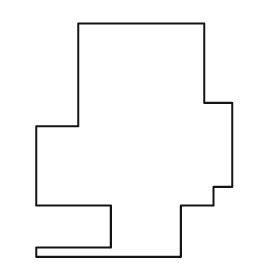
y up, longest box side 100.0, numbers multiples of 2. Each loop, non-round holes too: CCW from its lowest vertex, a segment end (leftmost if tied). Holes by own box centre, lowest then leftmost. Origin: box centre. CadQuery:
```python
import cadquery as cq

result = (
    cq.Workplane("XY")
    .moveTo(-42.0, -50.0)
    .lineTo(20.0, -50.0)
    .lineTo(20.0, -28.0)
    .lineTo(34.0, -28.0)
    .lineTo(34.0, -20.0)
    .lineTo(42.0, -20.0)
    .lineTo(42.0, 16.0)
    .lineTo(30.0, 16.0)
    .lineTo(30.0, 50.0)
    .lineTo(-24.0, 50.0)
    .lineTo(-24.0, 6.0)
    .lineTo(-42.0, 6.0)
    .lineTo(-42.0, -28.0)
    .lineTo(-10.0, -28.0)
    .lineTo(-10.0, -46.0)
    .lineTo(-42.0, -46.0)
    .close()
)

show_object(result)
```